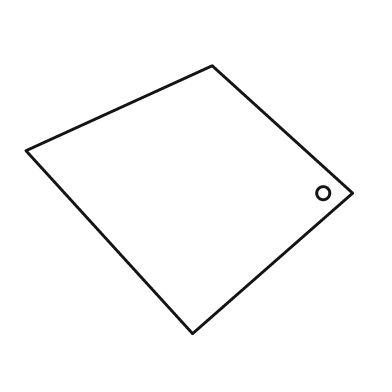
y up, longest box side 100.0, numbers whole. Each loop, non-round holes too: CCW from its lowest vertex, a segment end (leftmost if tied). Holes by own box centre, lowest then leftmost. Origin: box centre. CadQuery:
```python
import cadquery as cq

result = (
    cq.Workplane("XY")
    .moveTo(1.0, -41.0)
    .lineTo(50.0, 2.0)
    .lineTo(7.0, 41.0)
    .lineTo(-50.0, 15.0)
    .close()
    .moveTo(41.0, 2.0)
    .circle(2.0)
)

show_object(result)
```